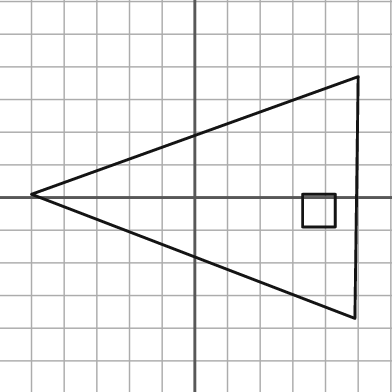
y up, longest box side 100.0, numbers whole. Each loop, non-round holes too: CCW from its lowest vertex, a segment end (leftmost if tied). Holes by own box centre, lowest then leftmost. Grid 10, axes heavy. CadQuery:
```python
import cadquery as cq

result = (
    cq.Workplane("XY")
    .moveTo(49.0, -37.0)
    .lineTo(50.0, 37.0)
    .lineTo(-50.0, 1.0)
    .close()
    .moveTo(33.0, -9.0)
    .lineTo(43.0, -9.0)
    .lineTo(43.0, 1.0)
    .lineTo(33.0, 1.0)
    .close()
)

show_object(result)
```